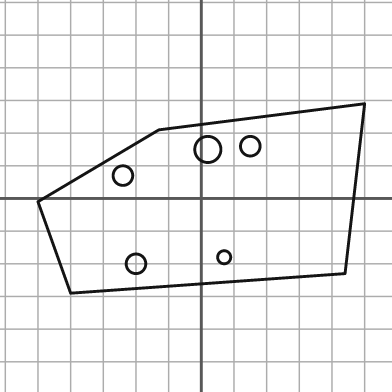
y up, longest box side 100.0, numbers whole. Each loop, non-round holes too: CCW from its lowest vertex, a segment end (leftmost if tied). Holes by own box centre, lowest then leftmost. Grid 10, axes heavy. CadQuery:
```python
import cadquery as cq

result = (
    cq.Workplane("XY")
    .moveTo(-40.0, -29.0)
    .lineTo(44.0, -23.0)
    .lineTo(50.0, 29.0)
    .lineTo(-13.0, 21.0)
    .lineTo(-50.0, -1.0)
    .close()
    .moveTo(-20.0, -20.0)
    .circle(3.0)
    .moveTo(7.0, -18.0)
    .circle(2.0)
    .moveTo(-24.0, 7.0)
    .circle(3.0)
    .moveTo(2.0, 15.0)
    .circle(4.0)
    .moveTo(15.0, 16.0)
    .circle(3.0)
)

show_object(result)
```